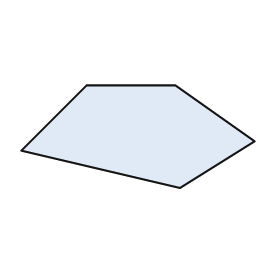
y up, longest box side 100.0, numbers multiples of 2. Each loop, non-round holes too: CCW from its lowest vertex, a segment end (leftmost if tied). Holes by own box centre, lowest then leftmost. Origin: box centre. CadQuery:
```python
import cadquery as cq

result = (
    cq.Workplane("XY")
    .moveTo(18.0, -22.0)
    .lineTo(50.0, -2.0)
    .lineTo(16.0, 22.0)
    .lineTo(-22.0, 22.0)
    .lineTo(-50.0, -6.0)
    .close()
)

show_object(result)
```